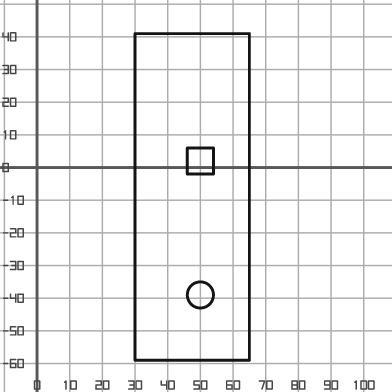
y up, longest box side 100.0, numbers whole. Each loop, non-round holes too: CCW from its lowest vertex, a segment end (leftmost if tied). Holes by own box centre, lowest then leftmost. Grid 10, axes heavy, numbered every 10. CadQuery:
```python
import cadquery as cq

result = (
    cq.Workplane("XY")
    .moveTo(30.0, -59.0)
    .lineTo(65.0, -59.0)
    .lineTo(65.0, 41.0)
    .lineTo(30.0, 41.0)
    .close()
    .moveTo(50.0, -39.0)
    .circle(4.0)
    .moveTo(46.0, -2.0)
    .lineTo(54.0, -2.0)
    .lineTo(54.0, 6.0)
    .lineTo(46.0, 6.0)
    .close()
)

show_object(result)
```